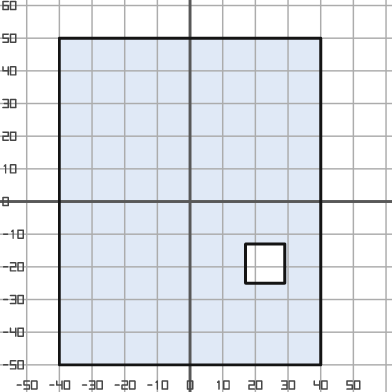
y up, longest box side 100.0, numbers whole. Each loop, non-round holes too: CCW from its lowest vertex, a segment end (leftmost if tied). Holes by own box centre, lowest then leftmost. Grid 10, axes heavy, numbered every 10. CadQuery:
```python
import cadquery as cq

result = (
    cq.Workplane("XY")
    .moveTo(-40.0, -50.0)
    .lineTo(40.0, -50.0)
    .lineTo(40.0, 50.0)
    .lineTo(-40.0, 50.0)
    .close()
    .moveTo(17.0, -25.0)
    .lineTo(29.0, -25.0)
    .lineTo(29.0, -13.0)
    .lineTo(17.0, -13.0)
    .close()
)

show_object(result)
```